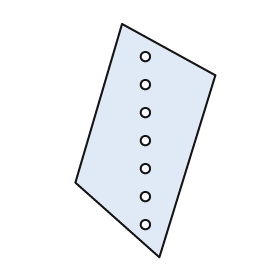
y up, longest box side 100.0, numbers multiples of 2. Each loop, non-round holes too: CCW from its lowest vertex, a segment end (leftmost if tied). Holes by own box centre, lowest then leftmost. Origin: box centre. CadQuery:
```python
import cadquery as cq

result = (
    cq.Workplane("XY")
    .moveTo(6.0, -50.0)
    .lineTo(30.0, 28.0)
    .lineTo(-10.0, 50.0)
    .lineTo(-30.0, -18.0)
    .close()
    .moveTo(0.0, -36.0)
    .circle(2.0)
    .moveTo(0.0, -24.0)
    .circle(2.0)
    .moveTo(0.0, -12.0)
    .circle(2.0)
    .moveTo(0.0, 0.0)
    .circle(2.0)
    .moveTo(0.0, 12.0)
    .circle(2.0)
    .moveTo(0.0, 24.0)
    .circle(2.0)
    .moveTo(0.0, 36.0)
    .circle(2.0)
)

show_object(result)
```